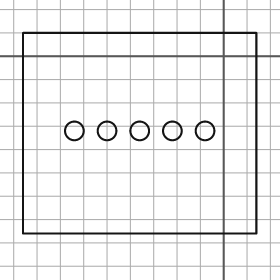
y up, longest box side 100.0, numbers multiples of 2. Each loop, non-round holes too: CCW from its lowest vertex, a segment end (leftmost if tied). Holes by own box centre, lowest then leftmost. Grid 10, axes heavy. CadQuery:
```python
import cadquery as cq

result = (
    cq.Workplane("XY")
    .moveTo(-86.0, -76.0)
    .lineTo(14.0, -76.0)
    .lineTo(14.0, 10.0)
    .lineTo(-86.0, 10.0)
    .close()
    .moveTo(-64.0, -32.0)
    .circle(4.0)
    .moveTo(-50.0, -32.0)
    .circle(4.0)
    .moveTo(-36.0, -32.0)
    .circle(4.0)
    .moveTo(-22.0, -32.0)
    .circle(4.0)
    .moveTo(-8.0, -32.0)
    .circle(4.0)
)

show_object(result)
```